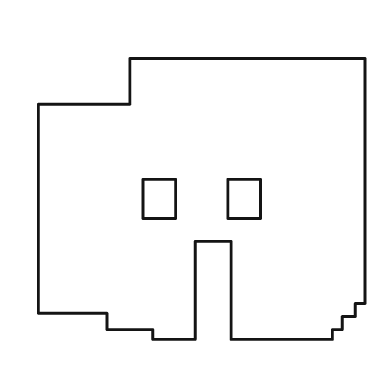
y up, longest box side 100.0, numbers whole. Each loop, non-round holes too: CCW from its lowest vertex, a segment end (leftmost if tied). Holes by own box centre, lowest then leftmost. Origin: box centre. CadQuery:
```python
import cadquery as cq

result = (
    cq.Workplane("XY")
    .moveTo(-15.0, -43.0)
    .lineTo(-2.0, -43.0)
    .lineTo(-2.0, -13.0)
    .lineTo(9.0, -13.0)
    .lineTo(9.0, -43.0)
    .lineTo(40.0, -43.0)
    .lineTo(40.0, -40.0)
    .lineTo(43.0, -40.0)
    .lineTo(43.0, -36.0)
    .lineTo(47.0, -36.0)
    .lineTo(47.0, -32.0)
    .lineTo(50.0, -32.0)
    .lineTo(50.0, 43.0)
    .lineTo(-22.0, 43.0)
    .lineTo(-22.0, 29.0)
    .lineTo(-50.0, 29.0)
    .lineTo(-50.0, -35.0)
    .lineTo(-29.0, -35.0)
    .lineTo(-29.0, -40.0)
    .lineTo(-15.0, -40.0)
    .close()
    .moveTo(-18.0, -6.0)
    .lineTo(-8.0, -6.0)
    .lineTo(-8.0, 6.0)
    .lineTo(-18.0, 6.0)
    .close()
    .moveTo(8.0, -6.0)
    .lineTo(18.0, -6.0)
    .lineTo(18.0, 6.0)
    .lineTo(8.0, 6.0)
    .close()
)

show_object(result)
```